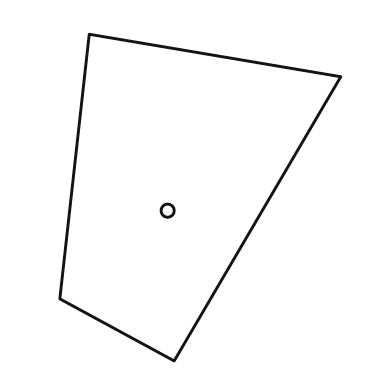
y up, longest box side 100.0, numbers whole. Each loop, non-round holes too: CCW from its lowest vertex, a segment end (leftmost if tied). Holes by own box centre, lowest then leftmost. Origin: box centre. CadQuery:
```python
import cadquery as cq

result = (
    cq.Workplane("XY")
    .moveTo(-8.0, -50.0)
    .lineTo(43.0, 37.0)
    .lineTo(-34.0, 50.0)
    .lineTo(-43.0, -31.0)
    .close()
    .moveTo(-10.0, -4.0)
    .circle(2.0)
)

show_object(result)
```